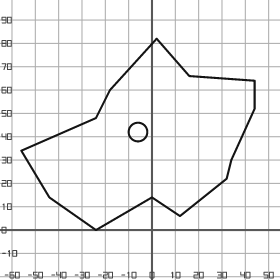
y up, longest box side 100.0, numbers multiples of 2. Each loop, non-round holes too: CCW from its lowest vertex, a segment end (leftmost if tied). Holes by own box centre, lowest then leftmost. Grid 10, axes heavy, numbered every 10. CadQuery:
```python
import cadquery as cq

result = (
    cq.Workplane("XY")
    .moveTo(-24.0, 0.0)
    .lineTo(0.0, 14.0)
    .lineTo(12.0, 6.0)
    .lineTo(32.0, 22.0)
    .lineTo(34.0, 30.0)
    .lineTo(44.0, 52.0)
    .lineTo(44.0, 64.0)
    .lineTo(16.0, 66.0)
    .lineTo(2.0, 82.0)
    .lineTo(-18.0, 60.0)
    .lineTo(-24.0, 48.0)
    .lineTo(-56.0, 34.0)
    .lineTo(-44.0, 14.0)
    .close()
    .moveTo(-6.0, 42.0)
    .circle(4.0)
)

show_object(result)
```